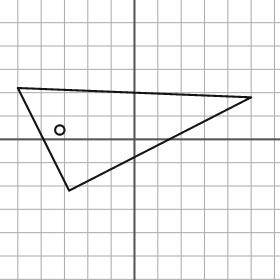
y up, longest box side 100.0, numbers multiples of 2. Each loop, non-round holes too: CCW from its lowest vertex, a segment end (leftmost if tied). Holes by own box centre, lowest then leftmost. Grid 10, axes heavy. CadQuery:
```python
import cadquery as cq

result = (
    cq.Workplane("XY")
    .moveTo(-28.0, -22.0)
    .lineTo(50.0, 18.0)
    .lineTo(-50.0, 22.0)
    .close()
    .moveTo(-32.0, 4.0)
    .circle(2.0)
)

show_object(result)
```